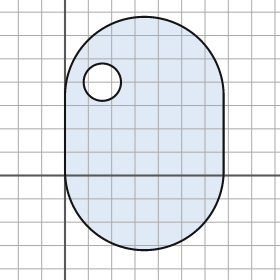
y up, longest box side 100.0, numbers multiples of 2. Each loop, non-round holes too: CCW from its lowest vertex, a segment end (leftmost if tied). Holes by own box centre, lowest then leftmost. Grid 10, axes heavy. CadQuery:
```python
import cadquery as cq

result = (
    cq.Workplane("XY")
    .moveTo(0.0, 2.0)
    .threePointArc((34.0, -32.0), (68.0, 2.0))
    .lineTo(68.0, 34.0)
    .threePointArc((34.0, 68.0), (0.0, 34.0))
    .close()
    .moveTo(16.0, 40.0)
    .circle(8.0)
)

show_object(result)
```